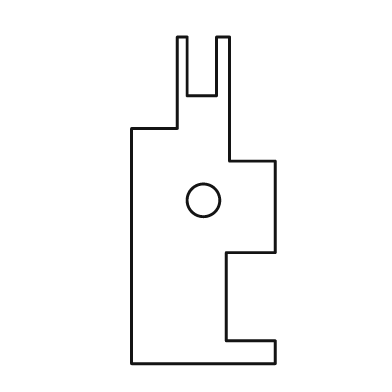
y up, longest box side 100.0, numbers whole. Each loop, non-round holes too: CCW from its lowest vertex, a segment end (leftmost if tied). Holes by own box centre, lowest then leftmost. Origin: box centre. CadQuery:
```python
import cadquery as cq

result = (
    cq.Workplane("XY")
    .moveTo(-22.0, -50.0)
    .lineTo(22.0, -50.0)
    .lineTo(22.0, -43.0)
    .lineTo(7.0, -43.0)
    .lineTo(7.0, -16.0)
    .lineTo(22.0, -16.0)
    .lineTo(22.0, 12.0)
    .lineTo(8.0, 12.0)
    .lineTo(8.0, 50.0)
    .lineTo(4.0, 50.0)
    .lineTo(4.0, 32.0)
    .lineTo(-5.0, 32.0)
    .lineTo(-5.0, 50.0)
    .lineTo(-8.0, 50.0)
    .lineTo(-8.0, 22.0)
    .lineTo(-22.0, 22.0)
    .close()
    .moveTo(0.0, 0.0)
    .circle(5.0)
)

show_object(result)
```